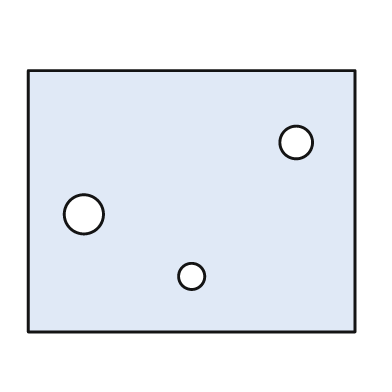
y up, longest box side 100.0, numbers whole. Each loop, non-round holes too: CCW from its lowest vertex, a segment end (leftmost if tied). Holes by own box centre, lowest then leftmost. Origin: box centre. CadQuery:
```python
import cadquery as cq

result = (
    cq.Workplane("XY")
    .moveTo(-50.0, -40.0)
    .lineTo(50.0, -40.0)
    .lineTo(50.0, 40.0)
    .lineTo(-50.0, 40.0)
    .close()
    .moveTo(0.0, -23.0)
    .circle(4.0)
    .moveTo(-33.0, -4.0)
    .circle(6.0)
    .moveTo(32.0, 18.0)
    .circle(5.0)
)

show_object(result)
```